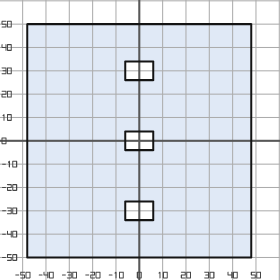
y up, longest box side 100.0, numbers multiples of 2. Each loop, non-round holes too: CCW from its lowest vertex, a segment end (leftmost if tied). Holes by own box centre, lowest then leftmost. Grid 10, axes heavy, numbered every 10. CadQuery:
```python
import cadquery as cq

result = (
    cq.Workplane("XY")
    .moveTo(-48.0, -50.0)
    .lineTo(48.0, -50.0)
    .lineTo(48.0, 50.0)
    .lineTo(-48.0, 50.0)
    .close()
    .moveTo(-6.0, -34.0)
    .lineTo(6.0, -34.0)
    .lineTo(6.0, -26.0)
    .lineTo(-6.0, -26.0)
    .close()
    .moveTo(-6.0, -4.0)
    .lineTo(6.0, -4.0)
    .lineTo(6.0, 4.0)
    .lineTo(-6.0, 4.0)
    .close()
    .moveTo(-6.0, 26.0)
    .lineTo(6.0, 26.0)
    .lineTo(6.0, 34.0)
    .lineTo(-6.0, 34.0)
    .close()
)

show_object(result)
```